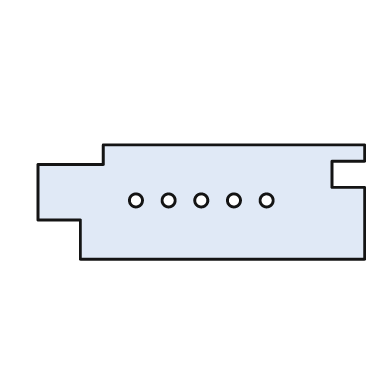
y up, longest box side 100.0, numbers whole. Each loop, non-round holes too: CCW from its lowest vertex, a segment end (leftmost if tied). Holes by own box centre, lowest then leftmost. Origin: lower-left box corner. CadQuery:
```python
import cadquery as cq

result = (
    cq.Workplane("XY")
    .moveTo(13.0, 0.0)
    .lineTo(100.0, 0.0)
    .lineTo(100.0, 22.0)
    .lineTo(90.0, 22.0)
    .lineTo(90.0, 30.0)
    .lineTo(100.0, 30.0)
    .lineTo(100.0, 35.0)
    .lineTo(20.0, 35.0)
    .lineTo(20.0, 29.0)
    .lineTo(0.0, 29.0)
    .lineTo(0.0, 12.0)
    .lineTo(13.0, 12.0)
    .close()
    .moveTo(30.0, 18.0)
    .circle(2.0)
    .moveTo(40.0, 18.0)
    .circle(2.0)
    .moveTo(50.0, 18.0)
    .circle(2.0)
    .moveTo(60.0, 18.0)
    .circle(2.0)
    .moveTo(70.0, 18.0)
    .circle(2.0)
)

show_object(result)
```